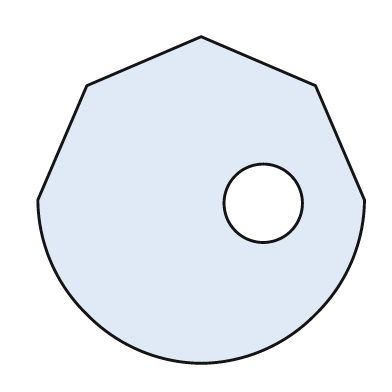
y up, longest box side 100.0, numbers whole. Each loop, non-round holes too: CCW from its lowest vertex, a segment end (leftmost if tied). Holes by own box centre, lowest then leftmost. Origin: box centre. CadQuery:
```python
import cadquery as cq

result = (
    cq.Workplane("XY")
    .moveTo(0.0, -50.0)
    .threePointArc((19.0, -46.0), (35.0, -35.0))
    .threePointArc((46.0, -19.0), (50.0, 0.0))
    .lineTo(35.0, 35.0)
    .lineTo(0.0, 50.0)
    .lineTo(-35.0, 35.0)
    .lineTo(-50.0, 0.0)
    .threePointArc((-46.0, -19.0), (-35.0, -35.0))
    .threePointArc((-19.0, -46.0), (0.0, -50.0))
    .close()
    .moveTo(19.0, -1.0)
    .circle(12.0)
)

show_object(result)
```